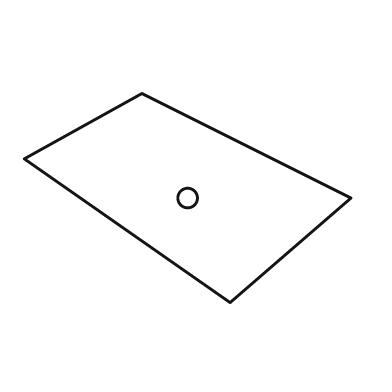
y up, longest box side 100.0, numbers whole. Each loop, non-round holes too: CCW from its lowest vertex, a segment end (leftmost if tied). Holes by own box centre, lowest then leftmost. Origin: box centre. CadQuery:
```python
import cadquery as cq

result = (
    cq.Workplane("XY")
    .moveTo(13.0, -32.0)
    .lineTo(50.0, 0.0)
    .lineTo(-14.0, 32.0)
    .lineTo(-50.0, 12.0)
    .close()
    .moveTo(0.0, 0.0)
    .circle(3.0)
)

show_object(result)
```